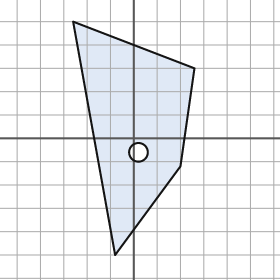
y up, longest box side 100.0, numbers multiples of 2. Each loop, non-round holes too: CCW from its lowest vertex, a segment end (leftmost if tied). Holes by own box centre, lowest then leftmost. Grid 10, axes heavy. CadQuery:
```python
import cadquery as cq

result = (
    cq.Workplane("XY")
    .moveTo(-8.0, -50.0)
    .lineTo(20.0, -12.0)
    .lineTo(26.0, 30.0)
    .lineTo(-26.0, 50.0)
    .close()
    .moveTo(2.0, -6.0)
    .circle(4.0)
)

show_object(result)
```